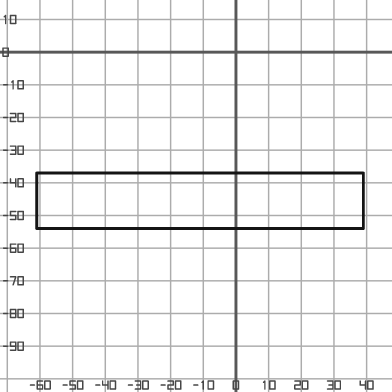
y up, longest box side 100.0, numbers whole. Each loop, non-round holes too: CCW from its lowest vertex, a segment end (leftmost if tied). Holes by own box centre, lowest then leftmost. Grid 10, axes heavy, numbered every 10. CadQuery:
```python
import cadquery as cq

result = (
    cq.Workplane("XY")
    .moveTo(-61.0, -54.0)
    .lineTo(39.0, -54.0)
    .lineTo(39.0, -37.0)
    .lineTo(-61.0, -37.0)
    .close()
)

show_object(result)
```